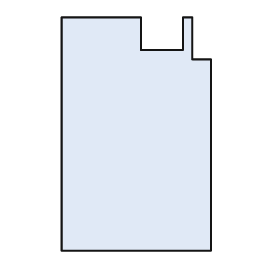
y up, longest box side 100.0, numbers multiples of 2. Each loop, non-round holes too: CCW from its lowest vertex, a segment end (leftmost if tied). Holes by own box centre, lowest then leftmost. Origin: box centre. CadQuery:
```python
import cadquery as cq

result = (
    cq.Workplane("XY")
    .moveTo(-32.0, -50.0)
    .lineTo(32.0, -50.0)
    .lineTo(32.0, 32.0)
    .lineTo(24.0, 32.0)
    .lineTo(24.0, 50.0)
    .lineTo(20.0, 50.0)
    .lineTo(20.0, 36.0)
    .lineTo(2.0, 36.0)
    .lineTo(2.0, 50.0)
    .lineTo(-32.0, 50.0)
    .close()
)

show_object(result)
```